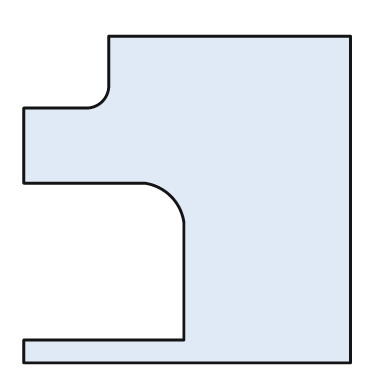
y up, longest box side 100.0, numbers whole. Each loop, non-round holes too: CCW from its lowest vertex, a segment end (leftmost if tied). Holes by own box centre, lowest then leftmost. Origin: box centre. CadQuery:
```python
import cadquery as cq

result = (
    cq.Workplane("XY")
    .moveTo(-50.0, -50.0)
    .lineTo(50.0, -50.0)
    .lineTo(50.0, 50.0)
    .lineTo(-24.0, 50.0)
    .lineTo(-24.0, 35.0)
    .threePointArc((-26.0, 30.0), (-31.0, 28.0))
    .lineTo(-50.0, 28.0)
    .lineTo(-50.0, 5.0)
    .lineTo(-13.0, 5.0)
    .threePointArc((-5.0, 1.0), (-1.0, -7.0))
    .lineTo(-1.0, -43.0)
    .lineTo(-50.0, -43.0)
    .close()
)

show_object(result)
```